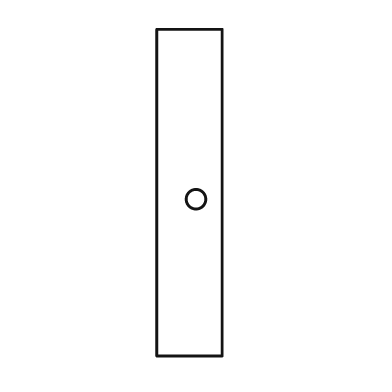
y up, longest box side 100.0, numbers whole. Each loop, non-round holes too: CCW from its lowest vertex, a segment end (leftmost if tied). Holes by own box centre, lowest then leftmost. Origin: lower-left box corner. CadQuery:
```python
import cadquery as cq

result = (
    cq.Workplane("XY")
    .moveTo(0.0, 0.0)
    .lineTo(20.0, 0.0)
    .lineTo(20.0, 100.0)
    .lineTo(0.0, 100.0)
    .close()
    .moveTo(12.0, 48.0)
    .circle(3.0)
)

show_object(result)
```